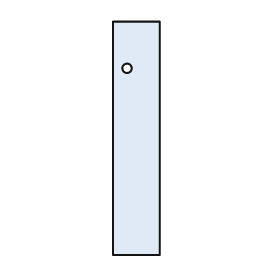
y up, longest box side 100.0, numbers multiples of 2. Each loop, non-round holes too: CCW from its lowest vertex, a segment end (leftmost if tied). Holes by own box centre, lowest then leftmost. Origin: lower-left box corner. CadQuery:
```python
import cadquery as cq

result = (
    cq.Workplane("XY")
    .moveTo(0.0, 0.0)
    .lineTo(20.0, 0.0)
    .lineTo(20.0, 100.0)
    .lineTo(0.0, 100.0)
    .close()
    .moveTo(6.0, 80.0)
    .circle(2.0)
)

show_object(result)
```